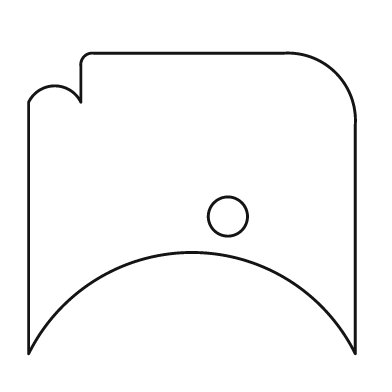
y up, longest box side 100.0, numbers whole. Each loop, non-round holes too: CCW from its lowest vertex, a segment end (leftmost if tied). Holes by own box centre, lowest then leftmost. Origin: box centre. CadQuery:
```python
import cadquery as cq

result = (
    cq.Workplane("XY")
    .moveTo(-50.0, -46.0)
    .threePointArc((0.0, -15.0), (50.0, -46.0))
    .lineTo(50.0, 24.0)
    .threePointArc((44.0, 40.0), (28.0, 46.0))
    .lineTo(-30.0, 46.0)
    .threePointArc((-33.0, 45.0), (-34.0, 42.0))
    .lineTo(-34.0, 31.0)
    .threePointArc((-42.0, 36.0), (-50.0, 31.0))
    .close()
    .moveTo(11.0, -4.0)
    .circle(6.0)
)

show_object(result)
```